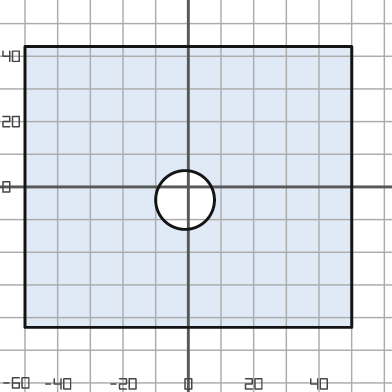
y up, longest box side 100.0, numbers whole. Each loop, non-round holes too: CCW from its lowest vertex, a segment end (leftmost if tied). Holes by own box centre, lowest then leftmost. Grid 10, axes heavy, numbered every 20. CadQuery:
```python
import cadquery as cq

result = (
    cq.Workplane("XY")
    .moveTo(-50.0, -43.0)
    .lineTo(50.0, -43.0)
    .lineTo(50.0, 43.0)
    .lineTo(-50.0, 43.0)
    .close()
    .moveTo(-1.0, -4.0)
    .circle(9.0)
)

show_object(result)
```